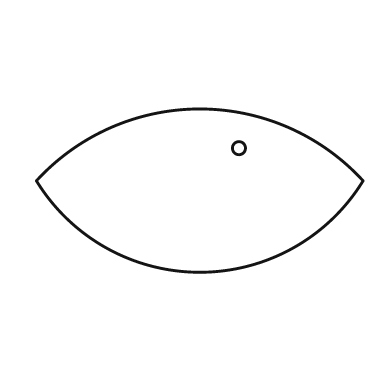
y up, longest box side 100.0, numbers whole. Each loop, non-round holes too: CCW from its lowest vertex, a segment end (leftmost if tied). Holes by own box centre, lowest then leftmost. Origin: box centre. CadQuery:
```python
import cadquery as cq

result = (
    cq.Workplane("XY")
    .moveTo(-50.0, 3.0)
    .threePointArc((0.0, -25.0), (50.0, 3.0))
    .threePointArc((0.0, 25.0), (-50.0, 3.0))
    .close()
    .moveTo(12.0, 13.0)
    .circle(2.0)
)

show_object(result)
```